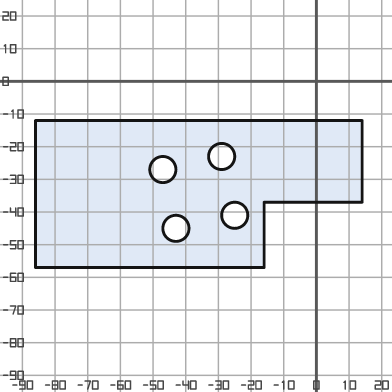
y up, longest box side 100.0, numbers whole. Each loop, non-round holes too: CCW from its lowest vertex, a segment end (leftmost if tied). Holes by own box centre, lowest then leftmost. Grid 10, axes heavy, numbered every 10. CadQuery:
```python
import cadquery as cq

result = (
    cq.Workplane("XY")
    .moveTo(-86.0, -57.0)
    .lineTo(-16.0, -57.0)
    .lineTo(-16.0, -37.0)
    .lineTo(14.0, -37.0)
    .lineTo(14.0, -12.0)
    .lineTo(-86.0, -12.0)
    .close()
    .moveTo(-43.0, -45.0)
    .circle(4.0)
    .moveTo(-25.0, -41.0)
    .circle(4.0)
    .moveTo(-47.0, -27.0)
    .circle(4.0)
    .moveTo(-29.0, -23.0)
    .circle(4.0)
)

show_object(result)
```